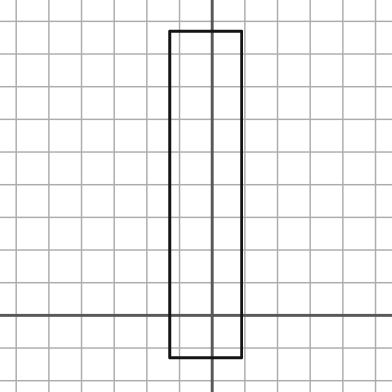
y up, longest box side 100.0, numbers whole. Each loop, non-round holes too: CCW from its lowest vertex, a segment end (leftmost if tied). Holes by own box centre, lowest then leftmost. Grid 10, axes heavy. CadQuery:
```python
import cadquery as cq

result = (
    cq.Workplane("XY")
    .moveTo(-13.0, -13.0)
    .lineTo(9.0, -13.0)
    .lineTo(9.0, 87.0)
    .lineTo(-13.0, 87.0)
    .close()
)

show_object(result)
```